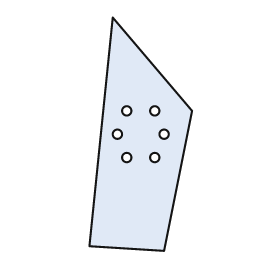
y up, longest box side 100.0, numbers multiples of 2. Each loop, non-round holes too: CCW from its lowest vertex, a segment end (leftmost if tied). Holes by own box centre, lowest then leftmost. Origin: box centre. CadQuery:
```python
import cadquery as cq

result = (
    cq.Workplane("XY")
    .moveTo(10.0, -50.0)
    .lineTo(22.0, 10.0)
    .lineTo(-12.0, 50.0)
    .lineTo(-22.0, -48.0)
    .close()
    .moveTo(-6.0, -10.0)
    .circle(2.0)
    .moveTo(6.0, -10.0)
    .circle(2.0)
    .moveTo(-10.0, 0.0)
    .circle(2.0)
    .moveTo(10.0, 0.0)
    .circle(2.0)
    .moveTo(-6.0, 10.0)
    .circle(2.0)
    .moveTo(6.0, 10.0)
    .circle(2.0)
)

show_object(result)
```